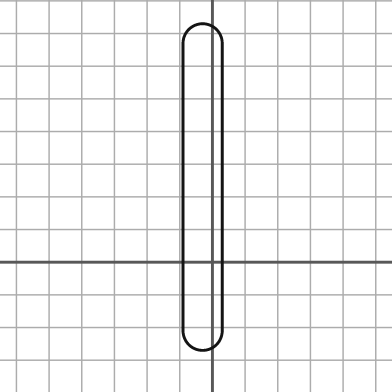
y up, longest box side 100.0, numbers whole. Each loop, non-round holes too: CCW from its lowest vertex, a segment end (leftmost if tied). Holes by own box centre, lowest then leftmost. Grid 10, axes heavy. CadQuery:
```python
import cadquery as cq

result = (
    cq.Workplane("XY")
    .moveTo(-9.0, -21.0)
    .threePointArc((-3.0, -27.0), (3.0, -21.0))
    .lineTo(3.0, 67.0)
    .threePointArc((-3.0, 73.0), (-9.0, 67.0))
    .close()
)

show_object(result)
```